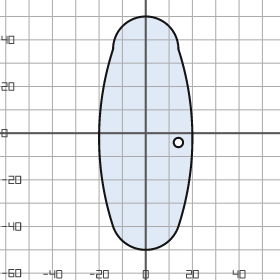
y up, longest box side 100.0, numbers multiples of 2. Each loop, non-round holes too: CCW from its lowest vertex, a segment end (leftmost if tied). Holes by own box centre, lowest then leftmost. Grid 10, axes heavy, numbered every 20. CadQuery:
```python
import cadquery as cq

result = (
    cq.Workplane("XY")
    .moveTo(-14.0, -40.0)
    .threePointArc((0.0, -50.0), (14.0, -40.0))
    .threePointArc((20.0, -2.0), (14.0, 36.0))
    .threePointArc((0.0, 50.0), (-14.0, 36.0))
    .threePointArc((-20.0, -2.0), (-14.0, -40.0))
    .close()
    .moveTo(14.0, -4.0)
    .circle(2.0)
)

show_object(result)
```